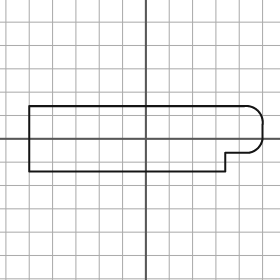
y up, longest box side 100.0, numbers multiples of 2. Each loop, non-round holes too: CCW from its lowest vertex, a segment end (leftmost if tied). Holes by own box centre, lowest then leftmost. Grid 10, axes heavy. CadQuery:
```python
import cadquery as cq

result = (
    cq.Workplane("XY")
    .moveTo(-50.0, -14.0)
    .lineTo(34.0, -14.0)
    .lineTo(34.0, -6.0)
    .lineTo(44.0, -6.0)
    .threePointArc((48.0, -4.0), (50.0, 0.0))
    .lineTo(50.0, 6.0)
    .threePointArc((48.0, 12.0), (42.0, 14.0))
    .lineTo(-50.0, 14.0)
    .close()
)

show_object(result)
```